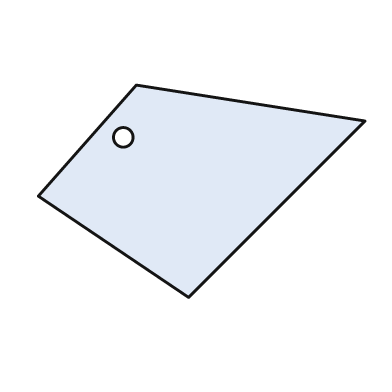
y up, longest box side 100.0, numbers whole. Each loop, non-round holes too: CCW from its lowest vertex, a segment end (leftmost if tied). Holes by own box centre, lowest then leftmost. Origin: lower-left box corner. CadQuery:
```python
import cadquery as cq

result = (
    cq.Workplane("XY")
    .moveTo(46.0, 0.0)
    .lineTo(100.0, 54.0)
    .lineTo(30.0, 65.0)
    .lineTo(0.0, 31.0)
    .close()
    .moveTo(26.0, 49.0)
    .circle(3.0)
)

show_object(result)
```